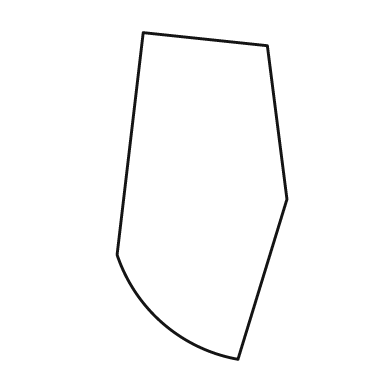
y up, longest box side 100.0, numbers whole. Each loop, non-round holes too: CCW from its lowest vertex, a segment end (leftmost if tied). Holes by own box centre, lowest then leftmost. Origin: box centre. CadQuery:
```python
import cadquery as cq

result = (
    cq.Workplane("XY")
    .moveTo(11.0, -50.0)
    .lineTo(26.0, -1.0)
    .lineTo(20.0, 46.0)
    .lineTo(-18.0, 50.0)
    .lineTo(-26.0, -18.0)
    .threePointArc((-12.0, -39.0), (11.0, -50.0))
    .close()
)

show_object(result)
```